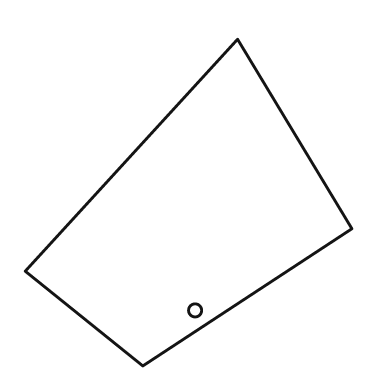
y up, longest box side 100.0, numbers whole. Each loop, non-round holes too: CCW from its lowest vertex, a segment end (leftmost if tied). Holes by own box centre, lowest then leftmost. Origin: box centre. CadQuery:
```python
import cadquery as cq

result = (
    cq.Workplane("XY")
    .moveTo(-14.0, -50.0)
    .lineTo(50.0, -8.0)
    .lineTo(15.0, 50.0)
    .lineTo(-50.0, -21.0)
    .close()
    .moveTo(2.0, -33.0)
    .circle(2.0)
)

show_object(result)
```